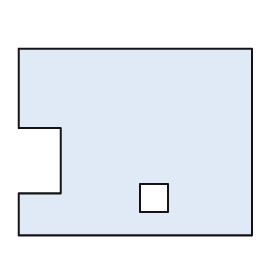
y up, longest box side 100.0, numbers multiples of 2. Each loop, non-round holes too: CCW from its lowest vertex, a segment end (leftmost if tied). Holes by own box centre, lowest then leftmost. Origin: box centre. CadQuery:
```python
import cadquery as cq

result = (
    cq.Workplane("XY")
    .moveTo(-50.0, -40.0)
    .lineTo(50.0, -40.0)
    .lineTo(50.0, 40.0)
    .lineTo(-50.0, 40.0)
    .lineTo(-50.0, 6.0)
    .lineTo(-32.0, 6.0)
    .lineTo(-32.0, -22.0)
    .lineTo(-50.0, -22.0)
    .close()
    .moveTo(2.0, -30.0)
    .lineTo(14.0, -30.0)
    .lineTo(14.0, -18.0)
    .lineTo(2.0, -18.0)
    .close()
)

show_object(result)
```